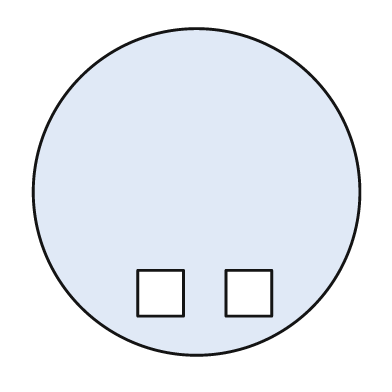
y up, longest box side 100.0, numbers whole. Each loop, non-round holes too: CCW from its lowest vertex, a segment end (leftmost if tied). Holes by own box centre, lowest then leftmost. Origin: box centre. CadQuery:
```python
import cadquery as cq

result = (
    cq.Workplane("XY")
    .moveTo(0.0, 0.0)
    .circle(50.0)
    .moveTo(-18.0, -38.0)
    .lineTo(-4.0, -38.0)
    .lineTo(-4.0, -24.0)
    .lineTo(-18.0, -24.0)
    .close()
    .moveTo(9.0, -38.0)
    .lineTo(23.0, -38.0)
    .lineTo(23.0, -24.0)
    .lineTo(9.0, -24.0)
    .close()
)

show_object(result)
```